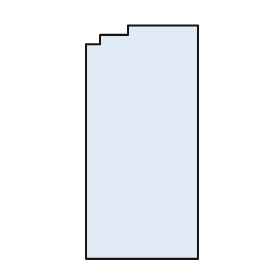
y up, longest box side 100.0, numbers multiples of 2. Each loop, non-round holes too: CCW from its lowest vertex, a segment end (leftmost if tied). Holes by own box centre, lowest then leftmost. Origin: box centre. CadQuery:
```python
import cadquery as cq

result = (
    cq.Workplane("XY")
    .moveTo(-24.0, -50.0)
    .lineTo(24.0, -50.0)
    .lineTo(24.0, 50.0)
    .lineTo(-6.0, 50.0)
    .lineTo(-6.0, 46.0)
    .lineTo(-18.0, 46.0)
    .lineTo(-18.0, 42.0)
    .lineTo(-24.0, 42.0)
    .close()
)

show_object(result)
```